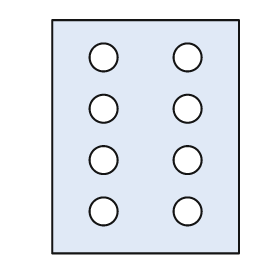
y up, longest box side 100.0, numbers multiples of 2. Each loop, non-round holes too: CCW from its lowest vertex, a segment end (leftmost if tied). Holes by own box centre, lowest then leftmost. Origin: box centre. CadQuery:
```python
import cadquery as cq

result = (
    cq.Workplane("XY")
    .moveTo(-40.0, -50.0)
    .lineTo(40.0, -50.0)
    .lineTo(40.0, 50.0)
    .lineTo(-40.0, 50.0)
    .close()
    .moveTo(-18.0, -32.0)
    .circle(6.0)
    .moveTo(18.0, -32.0)
    .circle(6.0)
    .moveTo(-18.0, -10.0)
    .circle(6.0)
    .moveTo(18.0, -10.0)
    .circle(6.0)
    .moveTo(-18.0, 12.0)
    .circle(6.0)
    .moveTo(18.0, 12.0)
    .circle(6.0)
    .moveTo(-18.0, 34.0)
    .circle(6.0)
    .moveTo(18.0, 34.0)
    .circle(6.0)
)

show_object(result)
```